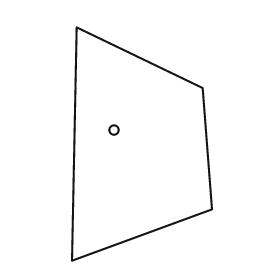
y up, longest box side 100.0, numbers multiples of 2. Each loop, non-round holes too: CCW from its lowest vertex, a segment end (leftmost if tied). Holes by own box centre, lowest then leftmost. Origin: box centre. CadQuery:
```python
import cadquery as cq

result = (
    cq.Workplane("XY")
    .moveTo(-30.0, -50.0)
    .lineTo(30.0, -28.0)
    .lineTo(26.0, 24.0)
    .lineTo(-28.0, 50.0)
    .close()
    .moveTo(-12.0, 6.0)
    .circle(2.0)
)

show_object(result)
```